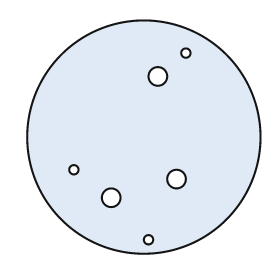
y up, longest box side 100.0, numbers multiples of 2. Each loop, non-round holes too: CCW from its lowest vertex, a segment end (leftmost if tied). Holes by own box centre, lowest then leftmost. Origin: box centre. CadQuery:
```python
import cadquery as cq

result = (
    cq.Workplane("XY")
    .moveTo(0.0, 0.0)
    .circle(50.0)
    .moveTo(2.0, -44.0)
    .circle(2.0)
    .moveTo(-14.0, -26.0)
    .circle(4.0)
    .moveTo(14.0, -18.0)
    .circle(4.0)
    .moveTo(-30.0, -14.0)
    .circle(2.0)
    .moveTo(6.0, 26.0)
    .circle(4.0)
    .moveTo(18.0, 36.0)
    .circle(2.0)
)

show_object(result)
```